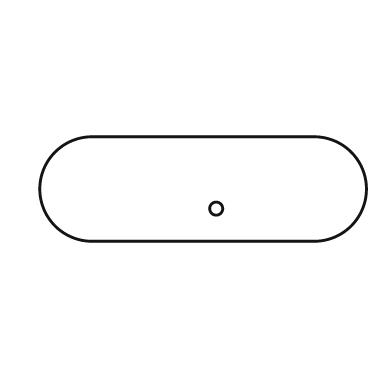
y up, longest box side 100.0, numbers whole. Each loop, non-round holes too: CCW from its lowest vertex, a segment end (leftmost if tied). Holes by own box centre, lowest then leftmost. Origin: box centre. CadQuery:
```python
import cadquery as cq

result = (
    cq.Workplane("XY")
    .moveTo(-34.0, -16.0)
    .lineTo(34.0, -16.0)
    .threePointArc((50.0, 0.0), (34.0, 16.0))
    .lineTo(-34.0, 16.0)
    .threePointArc((-50.0, 0.0), (-34.0, -16.0))
    .close()
    .moveTo(4.0, -6.0)
    .circle(2.0)
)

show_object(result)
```